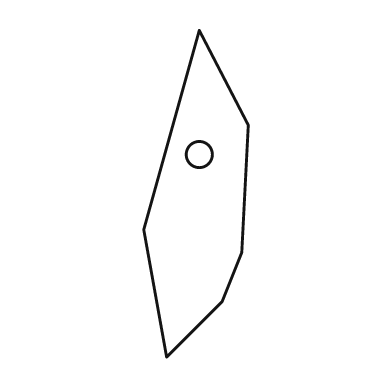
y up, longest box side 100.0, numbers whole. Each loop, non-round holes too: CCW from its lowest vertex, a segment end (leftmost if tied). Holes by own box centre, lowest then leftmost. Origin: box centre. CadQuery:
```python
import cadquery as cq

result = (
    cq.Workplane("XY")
    .moveTo(-9.0, -50.0)
    .lineTo(8.0, -33.0)
    .lineTo(14.0, -18.0)
    .lineTo(16.0, 21.0)
    .lineTo(1.0, 50.0)
    .lineTo(-16.0, -11.0)
    .close()
    .moveTo(1.0, 12.0)
    .circle(4.0)
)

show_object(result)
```